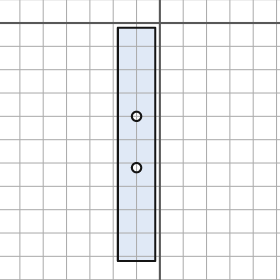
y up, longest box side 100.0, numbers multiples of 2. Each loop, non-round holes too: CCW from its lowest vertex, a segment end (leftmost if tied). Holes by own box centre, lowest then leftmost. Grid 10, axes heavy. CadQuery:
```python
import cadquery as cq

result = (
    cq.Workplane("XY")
    .moveTo(-18.0, -102.0)
    .lineTo(-2.0, -102.0)
    .lineTo(-2.0, -2.0)
    .lineTo(-18.0, -2.0)
    .close()
    .moveTo(-10.0, -62.0)
    .circle(2.0)
    .moveTo(-10.0, -40.0)
    .circle(2.0)
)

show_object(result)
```